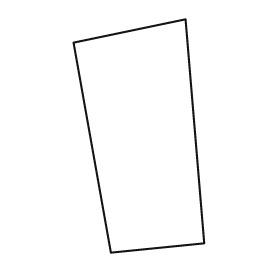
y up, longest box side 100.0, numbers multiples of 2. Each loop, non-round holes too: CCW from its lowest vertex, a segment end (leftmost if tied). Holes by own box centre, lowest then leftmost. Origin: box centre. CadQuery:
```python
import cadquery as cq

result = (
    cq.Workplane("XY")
    .moveTo(-12.0, -50.0)
    .lineTo(28.0, -46.0)
    .lineTo(20.0, 50.0)
    .lineTo(-28.0, 40.0)
    .close()
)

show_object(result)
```